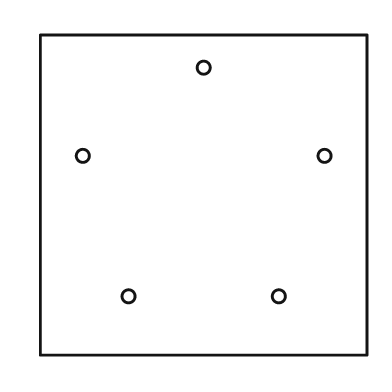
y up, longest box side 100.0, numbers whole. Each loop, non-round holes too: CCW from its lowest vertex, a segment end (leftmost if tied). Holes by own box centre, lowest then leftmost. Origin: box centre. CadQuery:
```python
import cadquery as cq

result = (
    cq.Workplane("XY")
    .moveTo(-50.0, -49.0)
    .lineTo(50.0, -49.0)
    .lineTo(50.0, 49.0)
    .lineTo(-50.0, 49.0)
    .close()
    .moveTo(-23.0, -31.0)
    .circle(2.0)
    .moveTo(23.0, -31.0)
    .circle(2.0)
    .moveTo(-37.0, 12.0)
    .circle(2.0)
    .moveTo(37.0, 12.0)
    .circle(2.0)
    .moveTo(0.0, 39.0)
    .circle(2.0)
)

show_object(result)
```